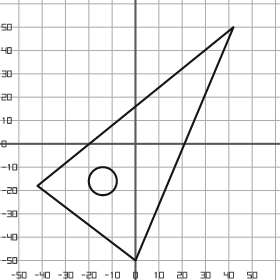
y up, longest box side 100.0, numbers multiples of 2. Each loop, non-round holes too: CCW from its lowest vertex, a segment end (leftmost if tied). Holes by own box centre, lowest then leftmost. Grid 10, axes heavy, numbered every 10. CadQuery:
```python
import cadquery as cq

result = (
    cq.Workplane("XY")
    .moveTo(0.0, -50.0)
    .lineTo(42.0, 50.0)
    .lineTo(-42.0, -18.0)
    .close()
    .moveTo(-14.0, -16.0)
    .circle(6.0)
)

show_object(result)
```